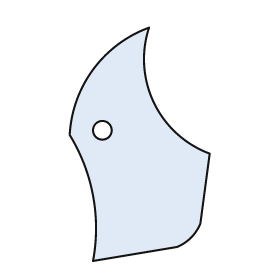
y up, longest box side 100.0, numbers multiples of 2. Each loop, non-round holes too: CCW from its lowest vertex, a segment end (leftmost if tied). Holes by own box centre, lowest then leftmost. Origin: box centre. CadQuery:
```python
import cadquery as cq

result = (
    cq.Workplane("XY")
    .moveTo(-20.0, -50.0)
    .lineTo(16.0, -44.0)
    .threePointArc((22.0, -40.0), (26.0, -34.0))
    .lineTo(30.0, -4.0)
    .threePointArc((6.0, 18.0), (4.0, 50.0))
    .threePointArc((-20.0, 32.0), (-30.0, 4.0))
    .threePointArc((-20.0, -22.0), (-20.0, -50.0))
    .close()
    .moveTo(-16.0, 6.0)
    .circle(4.0)
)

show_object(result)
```